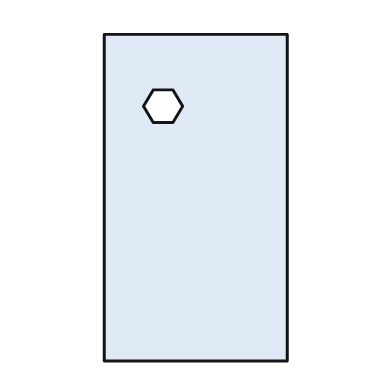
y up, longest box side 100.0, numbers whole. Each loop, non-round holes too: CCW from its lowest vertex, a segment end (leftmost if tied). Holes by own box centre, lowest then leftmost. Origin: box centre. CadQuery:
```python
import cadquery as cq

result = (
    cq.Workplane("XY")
    .moveTo(-28.0, -50.0)
    .lineTo(28.0, -50.0)
    .lineTo(28.0, 50.0)
    .lineTo(-28.0, 50.0)
    .close()
    .moveTo(-13.0, 23.0)
    .lineTo(-7.0, 23.0)
    .lineTo(-4.0, 28.0)
    .lineTo(-7.0, 33.0)
    .lineTo(-13.0, 33.0)
    .lineTo(-16.0, 28.0)
    .close()
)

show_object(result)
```